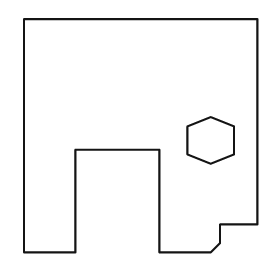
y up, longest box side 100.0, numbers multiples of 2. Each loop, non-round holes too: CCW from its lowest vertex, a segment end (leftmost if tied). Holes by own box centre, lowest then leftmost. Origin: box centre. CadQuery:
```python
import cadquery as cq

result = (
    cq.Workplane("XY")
    .moveTo(-50.0, -50.0)
    .lineTo(-28.0, -50.0)
    .lineTo(-28.0, -6.0)
    .lineTo(8.0, -6.0)
    .lineTo(8.0, -50.0)
    .lineTo(30.0, -50.0)
    .lineTo(34.0, -46.0)
    .lineTo(34.0, -38.0)
    .lineTo(50.0, -38.0)
    .lineTo(50.0, 50.0)
    .lineTo(-50.0, 50.0)
    .close()
    .moveTo(30.0, -12.0)
    .lineTo(40.0, -8.0)
    .lineTo(40.0, 4.0)
    .lineTo(30.0, 8.0)
    .lineTo(20.0, 4.0)
    .lineTo(20.0, -8.0)
    .close()
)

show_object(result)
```